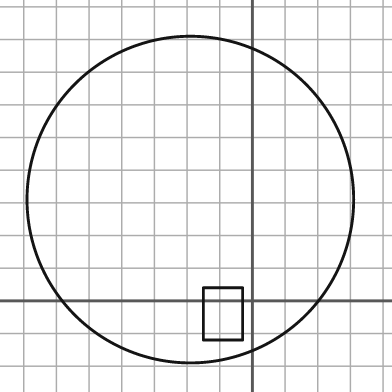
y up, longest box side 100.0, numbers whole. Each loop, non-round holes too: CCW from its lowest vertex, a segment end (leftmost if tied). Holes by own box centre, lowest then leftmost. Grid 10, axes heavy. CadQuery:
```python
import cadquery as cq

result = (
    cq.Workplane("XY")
    .moveTo(-19.0, 31.0)
    .circle(50.0)
    .moveTo(-15.0, -12.0)
    .lineTo(-3.0, -12.0)
    .lineTo(-3.0, 4.0)
    .lineTo(-15.0, 4.0)
    .close()
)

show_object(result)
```